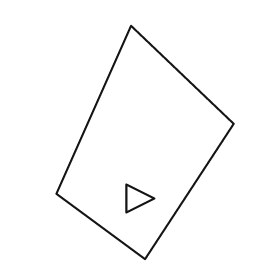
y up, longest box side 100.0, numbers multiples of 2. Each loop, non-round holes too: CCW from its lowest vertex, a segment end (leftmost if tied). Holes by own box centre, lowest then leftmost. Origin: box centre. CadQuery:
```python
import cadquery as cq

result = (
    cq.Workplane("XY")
    .moveTo(0.0, -50.0)
    .lineTo(38.0, 8.0)
    .lineTo(-6.0, 50.0)
    .lineTo(-38.0, -22.0)
    .close()
    .moveTo(-8.0, -30.0)
    .lineTo(4.0, -24.0)
    .lineTo(-8.0, -18.0)
    .close()
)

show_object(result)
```